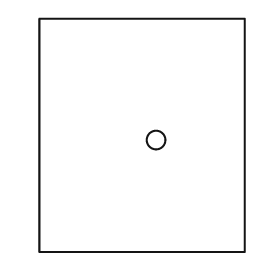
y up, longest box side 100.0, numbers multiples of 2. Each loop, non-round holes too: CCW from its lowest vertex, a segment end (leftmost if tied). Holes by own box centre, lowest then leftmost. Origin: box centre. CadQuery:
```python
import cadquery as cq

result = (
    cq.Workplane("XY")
    .moveTo(-44.0, -50.0)
    .lineTo(44.0, -50.0)
    .lineTo(44.0, 50.0)
    .lineTo(-44.0, 50.0)
    .close()
    .moveTo(6.0, -2.0)
    .circle(4.0)
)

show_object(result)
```